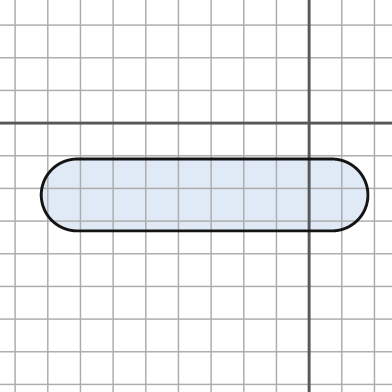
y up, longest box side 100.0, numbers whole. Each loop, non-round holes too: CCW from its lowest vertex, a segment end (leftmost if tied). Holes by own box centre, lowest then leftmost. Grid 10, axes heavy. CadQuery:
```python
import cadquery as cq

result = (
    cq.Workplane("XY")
    .moveTo(-71.0, -33.0)
    .lineTo(7.0, -33.0)
    .threePointArc((18.0, -22.0), (7.0, -11.0))
    .lineTo(-71.0, -11.0)
    .threePointArc((-82.0, -22.0), (-71.0, -33.0))
    .close()
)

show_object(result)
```